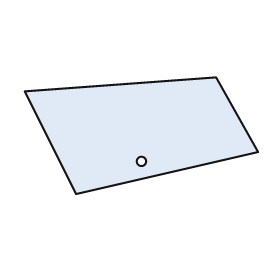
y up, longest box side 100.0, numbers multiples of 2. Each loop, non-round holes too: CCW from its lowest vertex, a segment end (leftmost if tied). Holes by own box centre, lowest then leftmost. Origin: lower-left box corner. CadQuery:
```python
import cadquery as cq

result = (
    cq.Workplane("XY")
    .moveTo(22.0, 0.0)
    .lineTo(100.0, 18.0)
    .lineTo(82.0, 50.0)
    .lineTo(0.0, 44.0)
    .close()
    .moveTo(50.0, 14.0)
    .circle(2.0)
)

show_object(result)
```